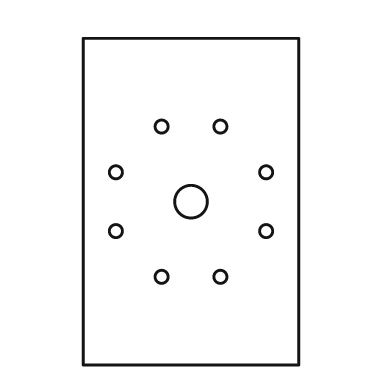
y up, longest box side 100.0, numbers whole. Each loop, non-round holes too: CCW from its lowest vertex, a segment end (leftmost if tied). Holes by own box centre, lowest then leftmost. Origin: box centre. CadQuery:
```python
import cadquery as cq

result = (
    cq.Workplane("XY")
    .moveTo(-33.0, -50.0)
    .lineTo(33.0, -50.0)
    .lineTo(33.0, 50.0)
    .lineTo(-33.0, 50.0)
    .close()
    .moveTo(-9.0, -23.0)
    .circle(2.0)
    .moveTo(9.0, -23.0)
    .circle(2.0)
    .moveTo(-23.0, -9.0)
    .circle(2.0)
    .moveTo(23.0, -9.0)
    .circle(2.0)
    .moveTo(0.0, 0.0)
    .circle(5.0)
    .moveTo(-23.0, 9.0)
    .circle(2.0)
    .moveTo(23.0, 9.0)
    .circle(2.0)
    .moveTo(-9.0, 23.0)
    .circle(2.0)
    .moveTo(9.0, 23.0)
    .circle(2.0)
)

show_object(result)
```